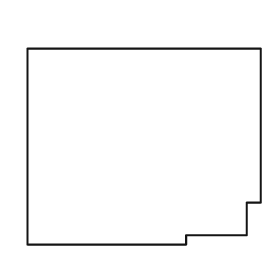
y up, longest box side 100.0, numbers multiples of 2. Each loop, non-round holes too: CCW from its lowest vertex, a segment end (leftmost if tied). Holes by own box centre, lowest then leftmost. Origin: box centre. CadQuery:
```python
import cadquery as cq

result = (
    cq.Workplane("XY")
    .moveTo(-50.0, -42.0)
    .lineTo(18.0, -42.0)
    .lineTo(18.0, -38.0)
    .lineTo(44.0, -38.0)
    .lineTo(44.0, -24.0)
    .lineTo(50.0, -24.0)
    .lineTo(50.0, 42.0)
    .lineTo(-50.0, 42.0)
    .close()
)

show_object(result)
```